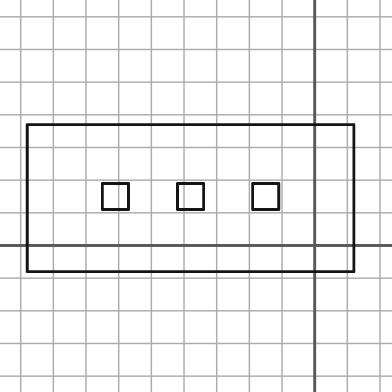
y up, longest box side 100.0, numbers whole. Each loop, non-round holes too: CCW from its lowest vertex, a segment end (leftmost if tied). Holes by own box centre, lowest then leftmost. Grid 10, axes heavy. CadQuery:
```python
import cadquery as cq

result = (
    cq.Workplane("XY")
    .moveTo(-88.0, -8.0)
    .lineTo(12.0, -8.0)
    .lineTo(12.0, 37.0)
    .lineTo(-88.0, 37.0)
    .close()
    .moveTo(-65.0, 11.0)
    .lineTo(-57.0, 11.0)
    .lineTo(-57.0, 19.0)
    .lineTo(-65.0, 19.0)
    .close()
    .moveTo(-42.0, 11.0)
    .lineTo(-34.0, 11.0)
    .lineTo(-34.0, 19.0)
    .lineTo(-42.0, 19.0)
    .close()
    .moveTo(-19.0, 11.0)
    .lineTo(-11.0, 11.0)
    .lineTo(-11.0, 19.0)
    .lineTo(-19.0, 19.0)
    .close()
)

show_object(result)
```